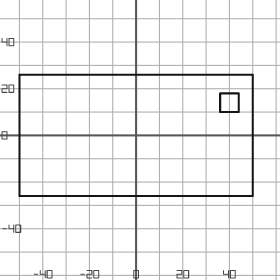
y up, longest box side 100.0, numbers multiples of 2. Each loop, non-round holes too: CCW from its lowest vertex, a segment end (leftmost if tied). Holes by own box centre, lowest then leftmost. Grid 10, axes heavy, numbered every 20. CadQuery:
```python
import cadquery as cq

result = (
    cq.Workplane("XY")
    .moveTo(-50.0, -26.0)
    .lineTo(50.0, -26.0)
    .lineTo(50.0, 26.0)
    .lineTo(-50.0, 26.0)
    .close()
    .moveTo(36.0, 10.0)
    .lineTo(44.0, 10.0)
    .lineTo(44.0, 18.0)
    .lineTo(36.0, 18.0)
    .close()
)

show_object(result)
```